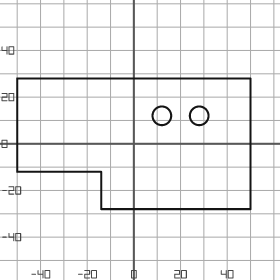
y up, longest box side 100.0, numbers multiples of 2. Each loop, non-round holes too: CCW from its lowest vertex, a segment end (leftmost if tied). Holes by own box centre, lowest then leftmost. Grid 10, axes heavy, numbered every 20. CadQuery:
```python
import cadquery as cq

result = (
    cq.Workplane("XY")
    .moveTo(-14.0, -28.0)
    .lineTo(50.0, -28.0)
    .lineTo(50.0, 28.0)
    .lineTo(-50.0, 28.0)
    .lineTo(-50.0, -12.0)
    .lineTo(-14.0, -12.0)
    .close()
    .moveTo(12.0, 12.0)
    .circle(4.0)
    .moveTo(28.0, 12.0)
    .circle(4.0)
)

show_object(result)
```